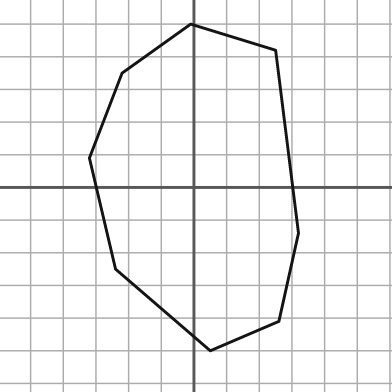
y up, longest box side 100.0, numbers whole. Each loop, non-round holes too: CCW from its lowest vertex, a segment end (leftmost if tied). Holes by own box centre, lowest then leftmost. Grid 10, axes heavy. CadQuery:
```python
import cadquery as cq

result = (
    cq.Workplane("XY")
    .moveTo(5.0, -50.0)
    .lineTo(26.0, -41.0)
    .lineTo(32.0, -14.0)
    .lineTo(25.0, 42.0)
    .lineTo(-1.0, 50.0)
    .lineTo(-22.0, 35.0)
    .lineTo(-32.0, 9.0)
    .lineTo(-24.0, -25.0)
    .close()
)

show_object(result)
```